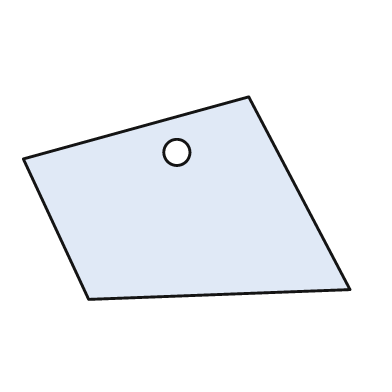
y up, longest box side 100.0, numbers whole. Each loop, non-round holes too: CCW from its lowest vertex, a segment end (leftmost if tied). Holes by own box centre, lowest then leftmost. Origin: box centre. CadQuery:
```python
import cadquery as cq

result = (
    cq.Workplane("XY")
    .moveTo(-30.0, -31.0)
    .lineTo(50.0, -28.0)
    .lineTo(19.0, 31.0)
    .lineTo(-50.0, 12.0)
    .close()
    .moveTo(-3.0, 14.0)
    .circle(4.0)
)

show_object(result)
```